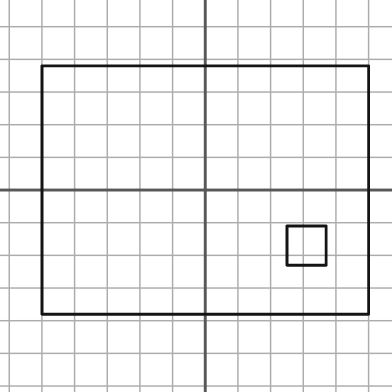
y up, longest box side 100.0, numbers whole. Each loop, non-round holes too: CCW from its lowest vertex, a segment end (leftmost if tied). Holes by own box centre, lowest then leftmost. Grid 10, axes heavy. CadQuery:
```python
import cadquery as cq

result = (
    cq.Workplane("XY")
    .moveTo(-50.0, -38.0)
    .lineTo(50.0, -38.0)
    .lineTo(50.0, 38.0)
    .lineTo(-50.0, 38.0)
    .close()
    .moveTo(25.0, -23.0)
    .lineTo(37.0, -23.0)
    .lineTo(37.0, -11.0)
    .lineTo(25.0, -11.0)
    .close()
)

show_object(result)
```